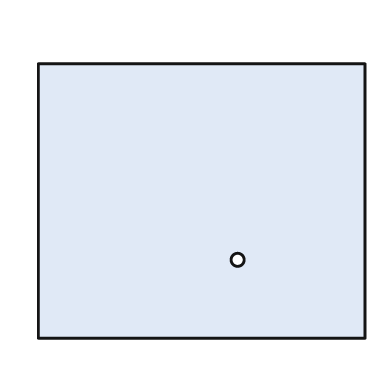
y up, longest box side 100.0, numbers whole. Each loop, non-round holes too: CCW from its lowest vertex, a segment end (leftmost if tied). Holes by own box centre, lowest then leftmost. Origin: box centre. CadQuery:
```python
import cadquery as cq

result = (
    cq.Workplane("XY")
    .moveTo(-50.0, -42.0)
    .lineTo(50.0, -42.0)
    .lineTo(50.0, 42.0)
    .lineTo(-50.0, 42.0)
    .close()
    .moveTo(11.0, -18.0)
    .circle(2.0)
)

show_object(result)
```